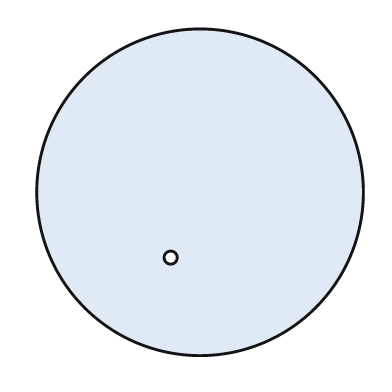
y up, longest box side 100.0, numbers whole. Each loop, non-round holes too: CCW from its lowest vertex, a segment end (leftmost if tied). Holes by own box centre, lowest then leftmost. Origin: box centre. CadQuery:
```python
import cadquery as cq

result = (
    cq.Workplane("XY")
    .moveTo(0.0, 0.0)
    .circle(50.0)
    .moveTo(-9.0, -20.0)
    .circle(2.0)
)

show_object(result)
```